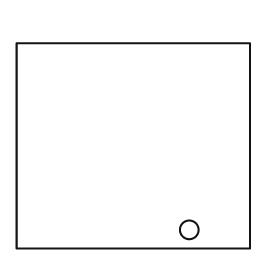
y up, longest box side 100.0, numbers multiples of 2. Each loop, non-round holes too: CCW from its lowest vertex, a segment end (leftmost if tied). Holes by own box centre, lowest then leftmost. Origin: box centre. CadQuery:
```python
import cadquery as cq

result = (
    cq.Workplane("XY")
    .moveTo(-50.0, -44.0)
    .lineTo(50.0, -44.0)
    .lineTo(50.0, 44.0)
    .lineTo(-50.0, 44.0)
    .close()
    .moveTo(24.0, -36.0)
    .circle(4.0)
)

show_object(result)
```